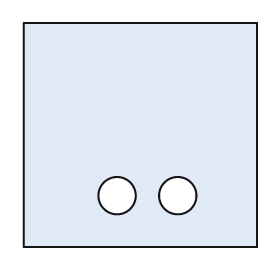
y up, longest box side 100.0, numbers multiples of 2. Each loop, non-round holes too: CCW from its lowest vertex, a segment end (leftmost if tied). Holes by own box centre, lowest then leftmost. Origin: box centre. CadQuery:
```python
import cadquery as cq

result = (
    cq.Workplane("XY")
    .moveTo(-50.0, -48.0)
    .lineTo(50.0, -48.0)
    .lineTo(50.0, 48.0)
    .lineTo(-50.0, 48.0)
    .close()
    .moveTo(-10.0, -26.0)
    .circle(8.0)
    .moveTo(16.0, -26.0)
    .circle(8.0)
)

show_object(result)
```